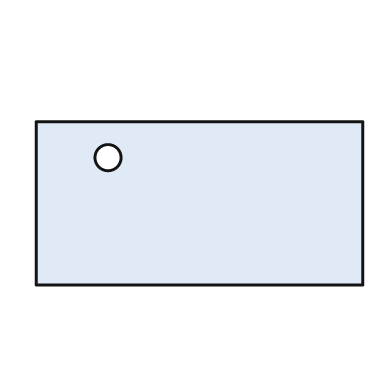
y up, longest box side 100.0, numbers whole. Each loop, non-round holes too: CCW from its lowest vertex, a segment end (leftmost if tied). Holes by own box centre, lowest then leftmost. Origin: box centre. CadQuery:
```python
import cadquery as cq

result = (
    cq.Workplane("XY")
    .moveTo(-50.0, -25.0)
    .lineTo(50.0, -25.0)
    .lineTo(50.0, 25.0)
    .lineTo(-50.0, 25.0)
    .close()
    .moveTo(-28.0, 14.0)
    .circle(4.0)
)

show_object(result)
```